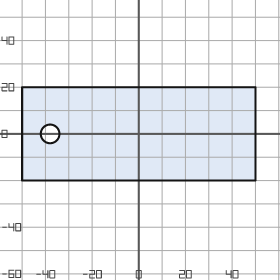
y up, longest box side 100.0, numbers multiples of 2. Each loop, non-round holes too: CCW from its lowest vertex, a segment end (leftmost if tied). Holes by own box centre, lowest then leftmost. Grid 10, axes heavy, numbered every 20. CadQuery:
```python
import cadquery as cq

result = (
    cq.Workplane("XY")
    .moveTo(-50.0, -20.0)
    .lineTo(50.0, -20.0)
    .lineTo(50.0, 20.0)
    .lineTo(-50.0, 20.0)
    .close()
    .moveTo(-38.0, 0.0)
    .circle(4.0)
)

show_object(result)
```